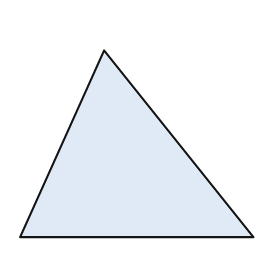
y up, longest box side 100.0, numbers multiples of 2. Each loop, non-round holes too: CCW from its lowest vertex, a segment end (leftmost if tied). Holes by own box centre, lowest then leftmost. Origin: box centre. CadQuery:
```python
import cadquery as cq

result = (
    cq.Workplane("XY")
    .moveTo(-50.0, -40.0)
    .lineTo(50.0, -40.0)
    .lineTo(-14.0, 40.0)
    .close()
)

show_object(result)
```